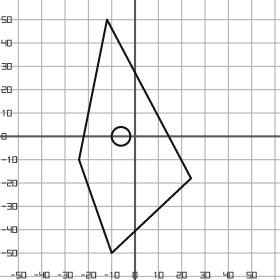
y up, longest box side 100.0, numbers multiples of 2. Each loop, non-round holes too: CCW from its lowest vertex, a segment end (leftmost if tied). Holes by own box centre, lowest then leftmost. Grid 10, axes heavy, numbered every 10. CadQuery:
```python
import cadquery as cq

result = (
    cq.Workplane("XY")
    .moveTo(-10.0, -50.0)
    .lineTo(24.0, -18.0)
    .lineTo(-12.0, 50.0)
    .lineTo(-24.0, -10.0)
    .close()
    .moveTo(-6.0, 0.0)
    .circle(4.0)
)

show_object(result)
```